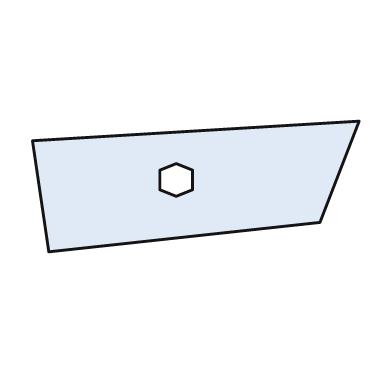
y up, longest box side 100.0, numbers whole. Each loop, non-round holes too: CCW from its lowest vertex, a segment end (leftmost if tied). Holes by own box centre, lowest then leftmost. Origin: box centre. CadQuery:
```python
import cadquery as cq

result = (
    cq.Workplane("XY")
    .moveTo(-45.0, -20.0)
    .lineTo(38.0, -11.0)
    .lineTo(50.0, 20.0)
    .lineTo(-50.0, 14.0)
    .close()
    .moveTo(-6.0, -3.0)
    .lineTo(-1.0, -1.0)
    .lineTo(-1.0, 5.0)
    .lineTo(-6.0, 7.0)
    .lineTo(-11.0, 5.0)
    .lineTo(-11.0, -1.0)
    .close()
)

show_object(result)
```